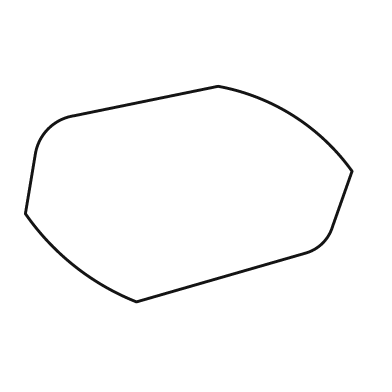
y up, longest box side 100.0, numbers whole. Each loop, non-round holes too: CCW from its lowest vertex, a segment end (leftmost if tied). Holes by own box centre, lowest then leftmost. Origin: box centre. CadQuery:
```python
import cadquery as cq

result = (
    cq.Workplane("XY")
    .moveTo(-16.0, -33.0)
    .lineTo(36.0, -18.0)
    .threePointArc((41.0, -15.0), (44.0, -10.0))
    .lineTo(50.0, 7.0)
    .threePointArc((32.0, 24.0), (9.0, 33.0))
    .lineTo(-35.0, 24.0)
    .threePointArc((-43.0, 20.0), (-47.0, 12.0))
    .lineTo(-50.0, -6.0)
    .threePointArc((-35.0, -22.0), (-16.0, -33.0))
    .close()
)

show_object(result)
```